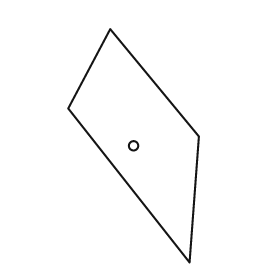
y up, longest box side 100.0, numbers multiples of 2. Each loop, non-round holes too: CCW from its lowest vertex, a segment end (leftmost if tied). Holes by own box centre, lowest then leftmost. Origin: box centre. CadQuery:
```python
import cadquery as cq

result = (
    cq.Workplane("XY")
    .moveTo(24.0, -50.0)
    .lineTo(28.0, 4.0)
    .lineTo(-10.0, 50.0)
    .lineTo(-28.0, 16.0)
    .close()
    .moveTo(0.0, 0.0)
    .circle(2.0)
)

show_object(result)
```